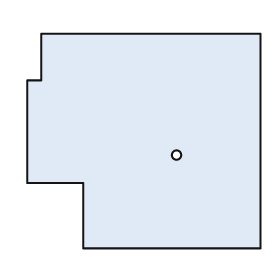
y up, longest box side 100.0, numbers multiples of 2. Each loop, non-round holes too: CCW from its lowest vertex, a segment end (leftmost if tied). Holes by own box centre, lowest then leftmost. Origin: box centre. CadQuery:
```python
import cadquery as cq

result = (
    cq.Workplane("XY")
    .moveTo(-26.0, -46.0)
    .lineTo(50.0, -46.0)
    .lineTo(50.0, 46.0)
    .lineTo(-44.0, 46.0)
    .lineTo(-44.0, 26.0)
    .lineTo(-50.0, 26.0)
    .lineTo(-50.0, -18.0)
    .lineTo(-26.0, -18.0)
    .close()
    .moveTo(14.0, -6.0)
    .circle(2.0)
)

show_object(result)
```